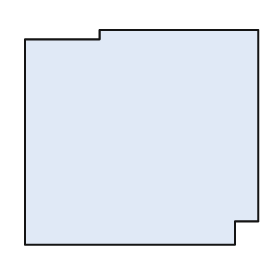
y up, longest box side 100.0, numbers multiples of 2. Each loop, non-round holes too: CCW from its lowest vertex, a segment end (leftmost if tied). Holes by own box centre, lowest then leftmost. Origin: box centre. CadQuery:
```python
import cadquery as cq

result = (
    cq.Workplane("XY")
    .moveTo(-50.0, -46.0)
    .lineTo(40.0, -46.0)
    .lineTo(40.0, -36.0)
    .lineTo(50.0, -36.0)
    .lineTo(50.0, 46.0)
    .lineTo(-18.0, 46.0)
    .lineTo(-18.0, 42.0)
    .lineTo(-50.0, 42.0)
    .close()
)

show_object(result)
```